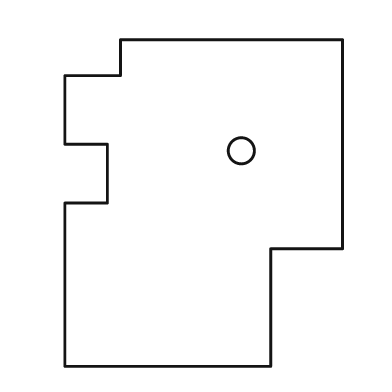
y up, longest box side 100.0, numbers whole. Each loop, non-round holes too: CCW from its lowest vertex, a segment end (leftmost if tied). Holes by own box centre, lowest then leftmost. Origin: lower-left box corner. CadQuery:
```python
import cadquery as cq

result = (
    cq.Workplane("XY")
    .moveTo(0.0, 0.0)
    .lineTo(63.0, 0.0)
    .lineTo(63.0, 36.0)
    .lineTo(85.0, 36.0)
    .lineTo(85.0, 100.0)
    .lineTo(17.0, 100.0)
    .lineTo(17.0, 89.0)
    .lineTo(0.0, 89.0)
    .lineTo(0.0, 68.0)
    .lineTo(13.0, 68.0)
    .lineTo(13.0, 50.0)
    .lineTo(0.0, 50.0)
    .close()
    .moveTo(54.0, 66.0)
    .circle(4.0)
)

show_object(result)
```